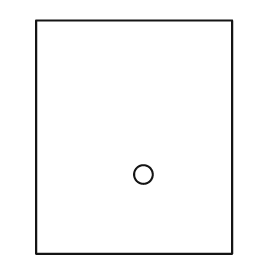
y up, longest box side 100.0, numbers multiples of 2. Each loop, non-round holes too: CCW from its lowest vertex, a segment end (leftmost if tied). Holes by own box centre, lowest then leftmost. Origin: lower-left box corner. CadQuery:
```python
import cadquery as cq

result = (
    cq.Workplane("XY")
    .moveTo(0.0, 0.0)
    .lineTo(84.0, 0.0)
    .lineTo(84.0, 100.0)
    .lineTo(0.0, 100.0)
    .close()
    .moveTo(46.0, 34.0)
    .circle(4.0)
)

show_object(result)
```